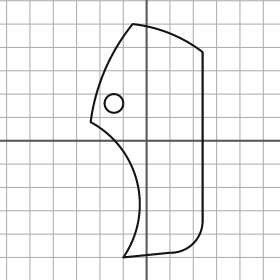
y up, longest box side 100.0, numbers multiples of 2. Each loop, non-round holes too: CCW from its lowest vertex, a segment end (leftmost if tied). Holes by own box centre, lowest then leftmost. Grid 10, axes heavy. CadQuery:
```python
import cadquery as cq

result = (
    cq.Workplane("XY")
    .moveTo(-10.0, -50.0)
    .lineTo(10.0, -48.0)
    .threePointArc((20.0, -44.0), (24.0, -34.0))
    .lineTo(24.0, 38.0)
    .threePointArc((10.0, 46.0), (-6.0, 50.0))
    .threePointArc((-18.0, 30.0), (-24.0, 8.0))
    .threePointArc((-4.0, -18.0), (-10.0, -50.0))
    .close()
    .moveTo(-14.0, 16.0)
    .circle(4.0)
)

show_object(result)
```